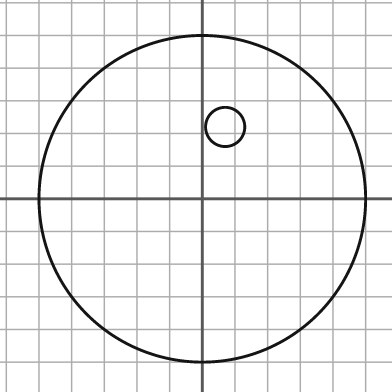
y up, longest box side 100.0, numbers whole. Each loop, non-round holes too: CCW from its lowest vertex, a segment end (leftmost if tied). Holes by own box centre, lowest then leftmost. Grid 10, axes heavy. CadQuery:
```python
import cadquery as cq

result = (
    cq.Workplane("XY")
    .moveTo(0.0, 0.0)
    .circle(50.0)
    .moveTo(7.0, 22.0)
    .circle(6.0)
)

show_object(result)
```